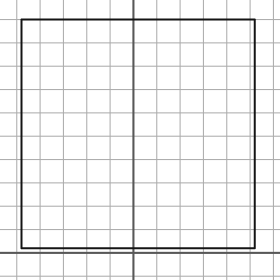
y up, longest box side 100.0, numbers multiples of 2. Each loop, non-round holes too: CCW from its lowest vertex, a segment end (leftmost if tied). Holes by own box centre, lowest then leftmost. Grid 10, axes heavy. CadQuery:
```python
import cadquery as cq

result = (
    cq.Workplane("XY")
    .moveTo(-48.0, 2.0)
    .lineTo(52.0, 2.0)
    .lineTo(52.0, 100.0)
    .lineTo(-48.0, 100.0)
    .close()
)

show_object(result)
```